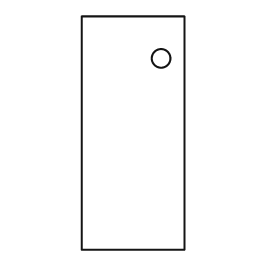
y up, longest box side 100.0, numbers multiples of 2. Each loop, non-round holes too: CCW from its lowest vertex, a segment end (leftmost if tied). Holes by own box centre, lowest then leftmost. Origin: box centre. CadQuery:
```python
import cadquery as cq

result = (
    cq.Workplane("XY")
    .moveTo(-22.0, -50.0)
    .lineTo(22.0, -50.0)
    .lineTo(22.0, 50.0)
    .lineTo(-22.0, 50.0)
    .close()
    .moveTo(12.0, 32.0)
    .circle(4.0)
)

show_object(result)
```